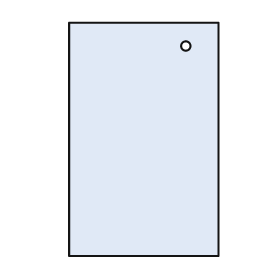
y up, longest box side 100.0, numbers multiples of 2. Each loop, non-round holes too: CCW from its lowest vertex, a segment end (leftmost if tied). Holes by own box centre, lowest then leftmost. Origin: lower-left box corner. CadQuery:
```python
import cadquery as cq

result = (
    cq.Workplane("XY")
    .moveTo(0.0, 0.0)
    .lineTo(64.0, 0.0)
    .lineTo(64.0, 100.0)
    .lineTo(0.0, 100.0)
    .close()
    .moveTo(50.0, 90.0)
    .circle(2.0)
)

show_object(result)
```